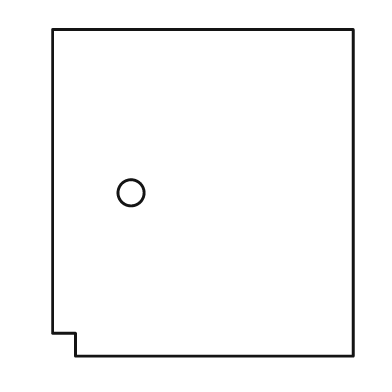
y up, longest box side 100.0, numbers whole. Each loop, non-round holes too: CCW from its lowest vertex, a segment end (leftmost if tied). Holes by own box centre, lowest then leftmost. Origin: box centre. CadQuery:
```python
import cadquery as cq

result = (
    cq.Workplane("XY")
    .moveTo(-39.0, -50.0)
    .lineTo(46.0, -50.0)
    .lineTo(46.0, 50.0)
    .lineTo(-46.0, 50.0)
    .lineTo(-46.0, -43.0)
    .lineTo(-39.0, -43.0)
    .close()
    .moveTo(-22.0, 0.0)
    .circle(4.0)
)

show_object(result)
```